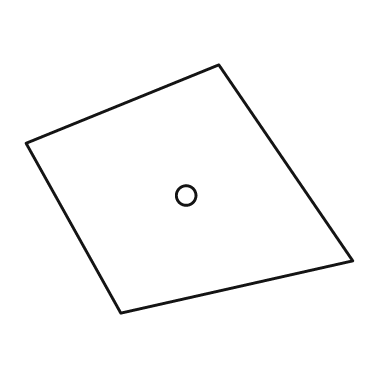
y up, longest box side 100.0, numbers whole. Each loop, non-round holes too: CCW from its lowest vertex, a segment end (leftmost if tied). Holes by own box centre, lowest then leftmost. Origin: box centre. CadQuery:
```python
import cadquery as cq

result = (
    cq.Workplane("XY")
    .moveTo(-21.0, -38.0)
    .lineTo(50.0, -22.0)
    .lineTo(9.0, 38.0)
    .lineTo(-50.0, 14.0)
    .close()
    .moveTo(-1.0, -2.0)
    .circle(3.0)
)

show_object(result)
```